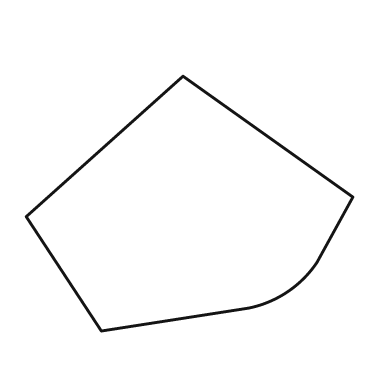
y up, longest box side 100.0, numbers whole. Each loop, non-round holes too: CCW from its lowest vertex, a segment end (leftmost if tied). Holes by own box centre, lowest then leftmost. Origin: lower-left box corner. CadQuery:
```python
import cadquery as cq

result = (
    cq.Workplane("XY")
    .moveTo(23.0, 0.0)
    .lineTo(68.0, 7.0)
    .threePointArc((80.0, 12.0), (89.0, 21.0))
    .lineTo(100.0, 41.0)
    .lineTo(48.0, 78.0)
    .lineTo(0.0, 35.0)
    .close()
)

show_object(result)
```